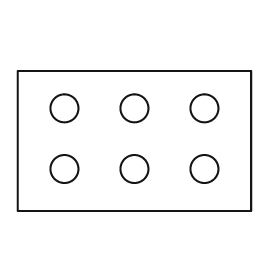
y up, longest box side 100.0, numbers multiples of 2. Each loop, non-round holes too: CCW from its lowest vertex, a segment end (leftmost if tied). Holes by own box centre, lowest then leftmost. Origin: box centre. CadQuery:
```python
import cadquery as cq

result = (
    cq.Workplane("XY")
    .moveTo(-50.0, -30.0)
    .lineTo(50.0, -30.0)
    .lineTo(50.0, 30.0)
    .lineTo(-50.0, 30.0)
    .close()
    .moveTo(-30.0, -12.0)
    .circle(6.0)
    .moveTo(0.0, -12.0)
    .circle(6.0)
    .moveTo(30.0, -12.0)
    .circle(6.0)
    .moveTo(-30.0, 14.0)
    .circle(6.0)
    .moveTo(0.0, 14.0)
    .circle(6.0)
    .moveTo(30.0, 14.0)
    .circle(6.0)
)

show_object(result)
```